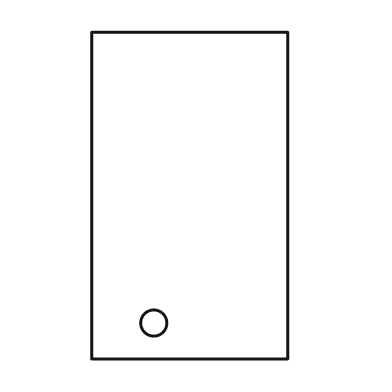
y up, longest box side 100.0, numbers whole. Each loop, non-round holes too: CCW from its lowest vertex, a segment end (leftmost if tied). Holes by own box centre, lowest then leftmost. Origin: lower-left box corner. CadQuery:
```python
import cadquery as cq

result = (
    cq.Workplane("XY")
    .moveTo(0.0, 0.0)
    .lineTo(60.0, 0.0)
    .lineTo(60.0, 100.0)
    .lineTo(0.0, 100.0)
    .close()
    .moveTo(19.0, 11.0)
    .circle(4.0)
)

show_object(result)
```